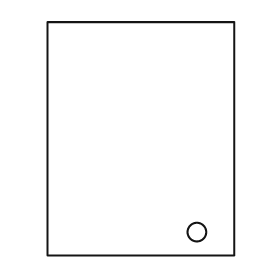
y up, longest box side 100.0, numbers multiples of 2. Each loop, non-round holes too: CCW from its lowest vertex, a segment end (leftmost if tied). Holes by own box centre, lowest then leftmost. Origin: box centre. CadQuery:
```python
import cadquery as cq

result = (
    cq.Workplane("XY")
    .moveTo(-40.0, -50.0)
    .lineTo(40.0, -50.0)
    .lineTo(40.0, 50.0)
    .lineTo(-40.0, 50.0)
    .close()
    .moveTo(24.0, -40.0)
    .circle(4.0)
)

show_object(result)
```